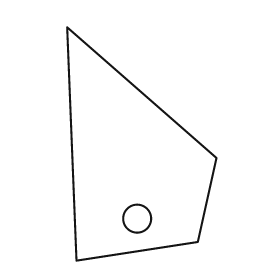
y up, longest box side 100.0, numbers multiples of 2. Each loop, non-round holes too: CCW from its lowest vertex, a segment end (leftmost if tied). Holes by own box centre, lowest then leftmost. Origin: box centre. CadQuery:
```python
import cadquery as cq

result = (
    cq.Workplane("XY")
    .moveTo(-28.0, -50.0)
    .lineTo(24.0, -42.0)
    .lineTo(32.0, -6.0)
    .lineTo(-32.0, 50.0)
    .close()
    .moveTo(-2.0, -32.0)
    .circle(6.0)
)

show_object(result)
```